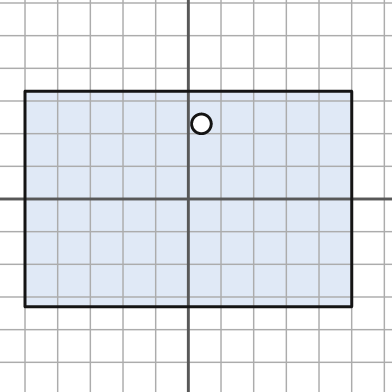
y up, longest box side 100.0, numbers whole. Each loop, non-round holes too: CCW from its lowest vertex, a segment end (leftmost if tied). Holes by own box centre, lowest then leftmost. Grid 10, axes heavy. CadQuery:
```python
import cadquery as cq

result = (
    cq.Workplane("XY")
    .moveTo(-50.0, -33.0)
    .lineTo(50.0, -33.0)
    .lineTo(50.0, 33.0)
    .lineTo(-50.0, 33.0)
    .close()
    .moveTo(4.0, 23.0)
    .circle(3.0)
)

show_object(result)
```